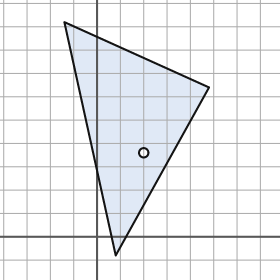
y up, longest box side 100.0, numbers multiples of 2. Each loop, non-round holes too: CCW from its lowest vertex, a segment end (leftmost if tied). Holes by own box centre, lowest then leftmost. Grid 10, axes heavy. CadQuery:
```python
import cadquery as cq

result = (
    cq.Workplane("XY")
    .moveTo(8.0, -8.0)
    .lineTo(48.0, 64.0)
    .lineTo(-14.0, 92.0)
    .close()
    .moveTo(20.0, 36.0)
    .circle(2.0)
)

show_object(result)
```